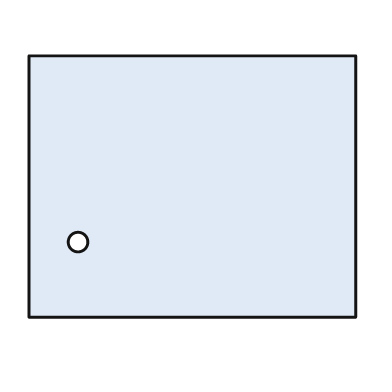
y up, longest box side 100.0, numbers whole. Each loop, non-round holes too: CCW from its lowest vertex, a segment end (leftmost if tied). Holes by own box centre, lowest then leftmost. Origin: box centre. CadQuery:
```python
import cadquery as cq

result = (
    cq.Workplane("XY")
    .moveTo(-50.0, -40.0)
    .lineTo(50.0, -40.0)
    .lineTo(50.0, 40.0)
    .lineTo(-50.0, 40.0)
    .close()
    .moveTo(-35.0, -17.0)
    .circle(3.0)
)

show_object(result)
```